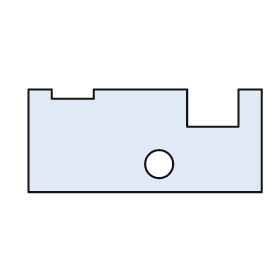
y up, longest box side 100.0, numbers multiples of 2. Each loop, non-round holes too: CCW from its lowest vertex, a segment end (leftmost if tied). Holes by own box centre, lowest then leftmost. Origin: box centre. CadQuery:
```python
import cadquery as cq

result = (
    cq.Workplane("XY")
    .moveTo(-50.0, -22.0)
    .lineTo(50.0, -22.0)
    .lineTo(50.0, 22.0)
    .lineTo(40.0, 22.0)
    .lineTo(40.0, 6.0)
    .lineTo(18.0, 6.0)
    .lineTo(18.0, 22.0)
    .lineTo(-22.0, 22.0)
    .lineTo(-22.0, 18.0)
    .lineTo(-40.0, 18.0)
    .lineTo(-40.0, 22.0)
    .lineTo(-50.0, 22.0)
    .close()
    .moveTo(6.0, -10.0)
    .circle(6.0)
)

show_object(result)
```